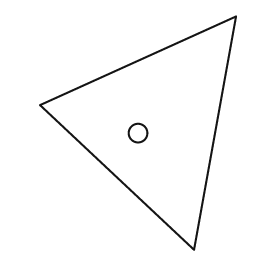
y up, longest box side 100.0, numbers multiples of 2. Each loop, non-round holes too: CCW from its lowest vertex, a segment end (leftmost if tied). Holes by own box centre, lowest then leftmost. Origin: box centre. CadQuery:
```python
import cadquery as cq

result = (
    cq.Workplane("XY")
    .moveTo(24.0, -50.0)
    .lineTo(42.0, 50.0)
    .lineTo(-42.0, 12.0)
    .close()
    .moveTo(0.0, 0.0)
    .circle(4.0)
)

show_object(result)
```